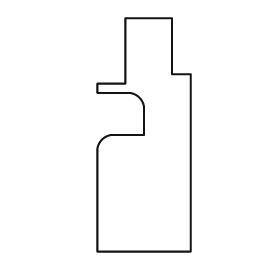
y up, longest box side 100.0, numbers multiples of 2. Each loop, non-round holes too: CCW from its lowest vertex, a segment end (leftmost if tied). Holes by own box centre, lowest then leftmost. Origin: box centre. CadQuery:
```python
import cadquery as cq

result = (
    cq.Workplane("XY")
    .moveTo(-20.0, -50.0)
    .lineTo(20.0, -50.0)
    .lineTo(20.0, 26.0)
    .lineTo(12.0, 26.0)
    .lineTo(12.0, 50.0)
    .lineTo(-8.0, 50.0)
    .lineTo(-8.0, 22.0)
    .lineTo(-20.0, 22.0)
    .lineTo(-20.0, 18.0)
    .lineTo(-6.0, 18.0)
    .threePointArc((-2.0, 16.0), (0.0, 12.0))
    .lineTo(0.0, 0.0)
    .lineTo(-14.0, 0.0)
    .threePointArc((-18.0, -2.0), (-20.0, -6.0))
    .close()
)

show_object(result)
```